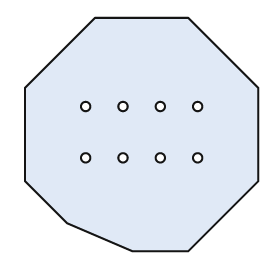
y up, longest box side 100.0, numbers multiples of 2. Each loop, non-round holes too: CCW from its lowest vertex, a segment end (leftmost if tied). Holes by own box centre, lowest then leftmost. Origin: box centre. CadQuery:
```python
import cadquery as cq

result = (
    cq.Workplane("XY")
    .moveTo(-4.0, -50.0)
    .lineTo(20.0, -50.0)
    .lineTo(50.0, -20.0)
    .lineTo(50.0, 20.0)
    .lineTo(20.0, 50.0)
    .lineTo(-20.0, 50.0)
    .lineTo(-50.0, 20.0)
    .lineTo(-50.0, -20.0)
    .lineTo(-32.0, -38.0)
    .close()
    .moveTo(-24.0, -10.0)
    .circle(2.0)
    .moveTo(-8.0, -10.0)
    .circle(2.0)
    .moveTo(8.0, -10.0)
    .circle(2.0)
    .moveTo(24.0, -10.0)
    .circle(2.0)
    .moveTo(-24.0, 12.0)
    .circle(2.0)
    .moveTo(-8.0, 12.0)
    .circle(2.0)
    .moveTo(8.0, 12.0)
    .circle(2.0)
    .moveTo(24.0, 12.0)
    .circle(2.0)
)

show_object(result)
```